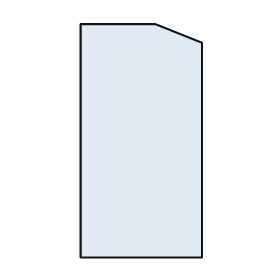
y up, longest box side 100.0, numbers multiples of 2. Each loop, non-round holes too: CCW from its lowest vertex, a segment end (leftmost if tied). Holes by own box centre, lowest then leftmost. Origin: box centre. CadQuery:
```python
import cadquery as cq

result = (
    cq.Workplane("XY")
    .moveTo(-26.0, -50.0)
    .lineTo(26.0, -50.0)
    .lineTo(26.0, 42.0)
    .lineTo(6.0, 50.0)
    .lineTo(-26.0, 50.0)
    .close()
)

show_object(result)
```